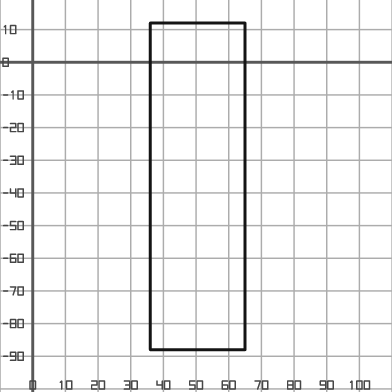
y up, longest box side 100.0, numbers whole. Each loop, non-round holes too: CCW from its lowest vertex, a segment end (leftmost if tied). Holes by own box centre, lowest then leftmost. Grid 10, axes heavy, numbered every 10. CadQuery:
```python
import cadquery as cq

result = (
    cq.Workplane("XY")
    .moveTo(36.0, -88.0)
    .lineTo(65.0, -88.0)
    .lineTo(65.0, 12.0)
    .lineTo(36.0, 12.0)
    .close()
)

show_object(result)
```